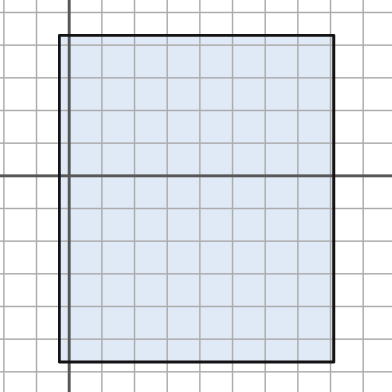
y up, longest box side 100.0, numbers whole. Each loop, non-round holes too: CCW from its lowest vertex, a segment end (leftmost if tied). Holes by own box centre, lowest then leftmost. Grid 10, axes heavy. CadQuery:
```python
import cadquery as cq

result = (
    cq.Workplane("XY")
    .moveTo(-3.0, -57.0)
    .lineTo(81.0, -57.0)
    .lineTo(81.0, 43.0)
    .lineTo(-3.0, 43.0)
    .close()
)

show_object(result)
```